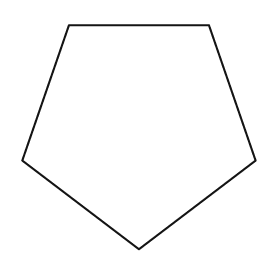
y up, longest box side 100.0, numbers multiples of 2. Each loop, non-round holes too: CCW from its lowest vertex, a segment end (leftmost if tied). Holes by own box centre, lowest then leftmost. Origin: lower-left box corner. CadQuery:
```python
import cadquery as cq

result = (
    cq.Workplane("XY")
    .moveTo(50.0, 0.0)
    .lineTo(100.0, 38.0)
    .lineTo(80.0, 96.0)
    .lineTo(20.0, 96.0)
    .lineTo(0.0, 38.0)
    .close()
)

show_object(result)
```